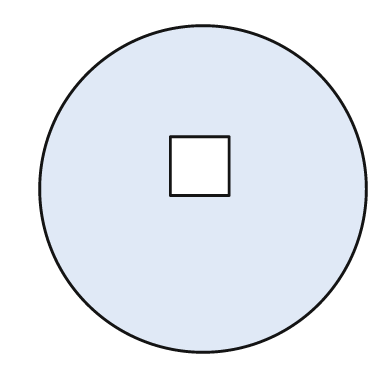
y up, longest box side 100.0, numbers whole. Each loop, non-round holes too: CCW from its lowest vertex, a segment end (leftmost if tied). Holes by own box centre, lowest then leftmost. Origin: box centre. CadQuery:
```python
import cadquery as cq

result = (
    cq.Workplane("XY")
    .moveTo(0.0, 0.0)
    .circle(50.0)
    .moveTo(-10.0, -2.0)
    .lineTo(8.0, -2.0)
    .lineTo(8.0, 16.0)
    .lineTo(-10.0, 16.0)
    .close()
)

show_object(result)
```